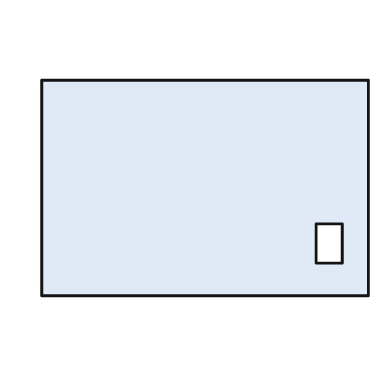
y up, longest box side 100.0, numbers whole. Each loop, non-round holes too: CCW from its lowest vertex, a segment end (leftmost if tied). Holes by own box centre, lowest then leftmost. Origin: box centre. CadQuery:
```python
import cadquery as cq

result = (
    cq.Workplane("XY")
    .moveTo(-50.0, -33.0)
    .lineTo(50.0, -33.0)
    .lineTo(50.0, 33.0)
    .lineTo(-50.0, 33.0)
    .close()
    .moveTo(34.0, -23.0)
    .lineTo(42.0, -23.0)
    .lineTo(42.0, -11.0)
    .lineTo(34.0, -11.0)
    .close()
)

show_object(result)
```